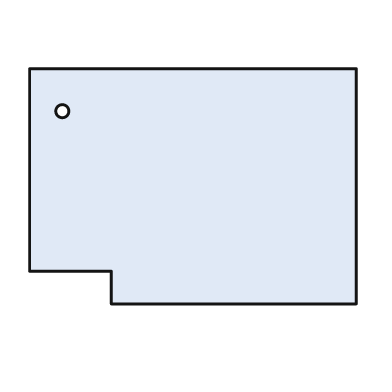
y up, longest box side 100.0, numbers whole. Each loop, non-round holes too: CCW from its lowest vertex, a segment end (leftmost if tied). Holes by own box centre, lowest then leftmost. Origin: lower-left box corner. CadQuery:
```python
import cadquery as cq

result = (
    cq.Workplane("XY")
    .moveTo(25.0, 0.0)
    .lineTo(100.0, 0.0)
    .lineTo(100.0, 72.0)
    .lineTo(0.0, 72.0)
    .lineTo(0.0, 10.0)
    .lineTo(25.0, 10.0)
    .close()
    .moveTo(10.0, 59.0)
    .circle(2.0)
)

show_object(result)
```